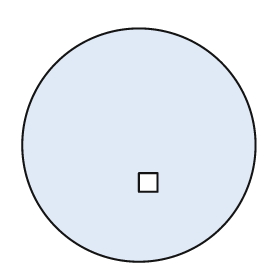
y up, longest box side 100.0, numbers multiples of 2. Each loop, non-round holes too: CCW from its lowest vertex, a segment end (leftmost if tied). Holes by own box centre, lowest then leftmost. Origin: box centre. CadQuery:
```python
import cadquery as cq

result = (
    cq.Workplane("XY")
    .moveTo(0.0, 0.0)
    .circle(50.0)
    .moveTo(0.0, -20.0)
    .lineTo(8.0, -20.0)
    .lineTo(8.0, -12.0)
    .lineTo(0.0, -12.0)
    .close()
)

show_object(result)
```